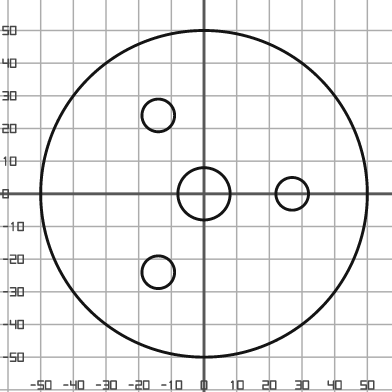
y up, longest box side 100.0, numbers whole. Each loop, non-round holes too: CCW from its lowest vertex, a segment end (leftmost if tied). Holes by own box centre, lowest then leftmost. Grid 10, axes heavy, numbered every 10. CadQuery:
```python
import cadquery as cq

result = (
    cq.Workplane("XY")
    .moveTo(0.0, 0.0)
    .circle(50.0)
    .moveTo(-14.0, -24.0)
    .circle(5.0)
    .moveTo(0.0, 0.0)
    .circle(8.0)
    .moveTo(27.0, 0.0)
    .circle(5.0)
    .moveTo(-14.0, 24.0)
    .circle(5.0)
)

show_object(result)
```